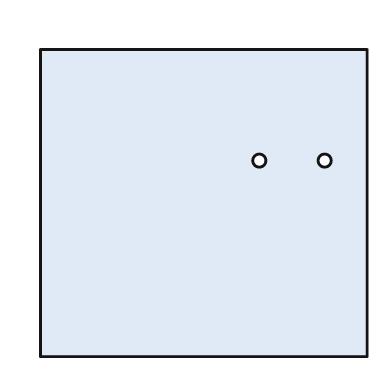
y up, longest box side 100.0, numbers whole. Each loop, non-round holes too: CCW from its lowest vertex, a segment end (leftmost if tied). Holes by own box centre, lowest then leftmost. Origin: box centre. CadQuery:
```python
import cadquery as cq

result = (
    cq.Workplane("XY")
    .moveTo(-50.0, -47.0)
    .lineTo(50.0, -47.0)
    .lineTo(50.0, 47.0)
    .lineTo(-50.0, 47.0)
    .close()
    .moveTo(17.0, 13.0)
    .circle(2.0)
    .moveTo(37.0, 13.0)
    .circle(2.0)
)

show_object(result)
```